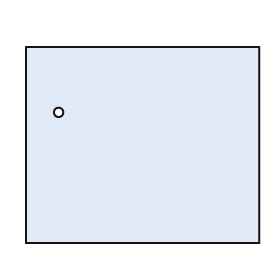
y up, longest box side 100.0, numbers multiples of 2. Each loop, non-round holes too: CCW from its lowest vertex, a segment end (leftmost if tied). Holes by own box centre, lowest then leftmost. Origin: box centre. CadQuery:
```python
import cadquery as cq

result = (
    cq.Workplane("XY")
    .moveTo(-50.0, -42.0)
    .lineTo(50.0, -42.0)
    .lineTo(50.0, 42.0)
    .lineTo(-50.0, 42.0)
    .close()
    .moveTo(-36.0, 14.0)
    .circle(2.0)
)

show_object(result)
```